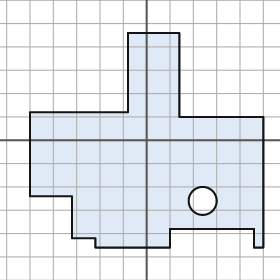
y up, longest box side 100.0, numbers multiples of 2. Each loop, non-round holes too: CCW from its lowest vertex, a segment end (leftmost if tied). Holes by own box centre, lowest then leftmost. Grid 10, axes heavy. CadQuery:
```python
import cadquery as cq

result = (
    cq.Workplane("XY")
    .moveTo(-22.0, -46.0)
    .lineTo(10.0, -46.0)
    .lineTo(10.0, -38.0)
    .lineTo(46.0, -38.0)
    .lineTo(46.0, -46.0)
    .lineTo(50.0, -46.0)
    .lineTo(50.0, 10.0)
    .lineTo(14.0, 10.0)
    .lineTo(14.0, 46.0)
    .lineTo(-8.0, 46.0)
    .lineTo(-8.0, 12.0)
    .lineTo(-50.0, 12.0)
    .lineTo(-50.0, -24.0)
    .lineTo(-32.0, -24.0)
    .lineTo(-32.0, -42.0)
    .lineTo(-22.0, -42.0)
    .close()
    .moveTo(24.0, -26.0)
    .circle(6.0)
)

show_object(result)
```